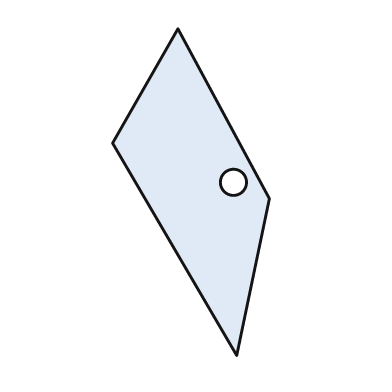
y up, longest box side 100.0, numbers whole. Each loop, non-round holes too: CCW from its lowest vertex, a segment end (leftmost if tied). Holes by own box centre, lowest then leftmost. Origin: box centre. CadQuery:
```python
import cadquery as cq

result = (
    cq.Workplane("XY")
    .moveTo(14.0, -50.0)
    .lineTo(24.0, -2.0)
    .lineTo(-4.0, 50.0)
    .lineTo(-24.0, 15.0)
    .close()
    .moveTo(13.0, 3.0)
    .circle(4.0)
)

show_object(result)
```